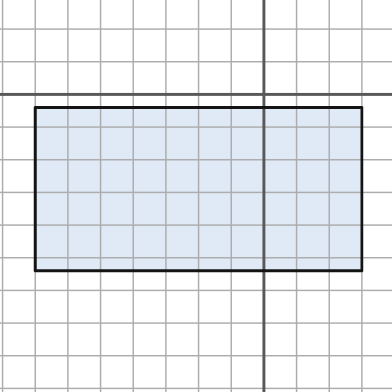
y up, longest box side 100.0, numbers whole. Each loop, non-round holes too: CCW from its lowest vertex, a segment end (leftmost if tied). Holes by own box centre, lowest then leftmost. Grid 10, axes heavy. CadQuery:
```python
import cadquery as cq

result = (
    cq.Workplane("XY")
    .moveTo(-70.0, -54.0)
    .lineTo(30.0, -54.0)
    .lineTo(30.0, -4.0)
    .lineTo(-70.0, -4.0)
    .close()
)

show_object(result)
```